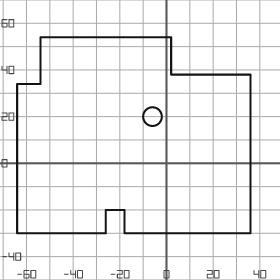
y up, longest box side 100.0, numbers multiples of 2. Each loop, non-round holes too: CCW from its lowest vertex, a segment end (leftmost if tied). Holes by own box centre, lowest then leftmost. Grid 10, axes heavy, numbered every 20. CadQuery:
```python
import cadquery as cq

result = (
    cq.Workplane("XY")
    .moveTo(-64.0, -30.0)
    .lineTo(-26.0, -30.0)
    .lineTo(-26.0, -20.0)
    .lineTo(-18.0, -20.0)
    .lineTo(-18.0, -30.0)
    .lineTo(36.0, -30.0)
    .lineTo(36.0, 38.0)
    .lineTo(2.0, 38.0)
    .lineTo(2.0, 54.0)
    .lineTo(-54.0, 54.0)
    .lineTo(-54.0, 34.0)
    .lineTo(-64.0, 34.0)
    .close()
    .moveTo(-6.0, 20.0)
    .circle(4.0)
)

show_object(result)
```